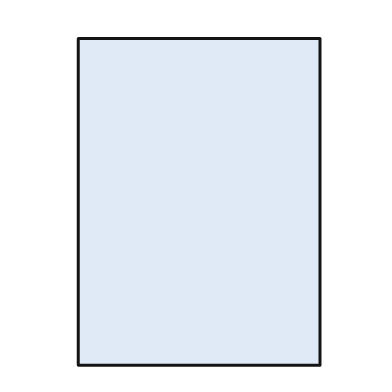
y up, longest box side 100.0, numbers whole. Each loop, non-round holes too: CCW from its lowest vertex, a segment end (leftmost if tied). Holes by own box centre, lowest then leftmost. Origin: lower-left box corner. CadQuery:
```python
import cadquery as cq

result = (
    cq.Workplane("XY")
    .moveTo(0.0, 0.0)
    .lineTo(74.0, 0.0)
    .lineTo(74.0, 100.0)
    .lineTo(0.0, 100.0)
    .close()
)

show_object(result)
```